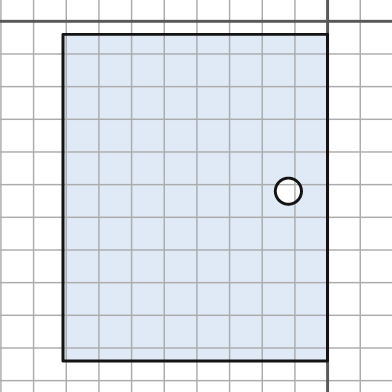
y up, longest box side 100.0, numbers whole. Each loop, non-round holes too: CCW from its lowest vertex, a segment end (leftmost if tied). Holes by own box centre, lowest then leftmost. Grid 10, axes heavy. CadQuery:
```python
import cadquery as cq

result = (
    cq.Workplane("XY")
    .moveTo(-81.0, -104.0)
    .lineTo(0.0, -104.0)
    .lineTo(0.0, -4.0)
    .lineTo(-81.0, -4.0)
    .close()
    .moveTo(-12.0, -52.0)
    .circle(4.0)
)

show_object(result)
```